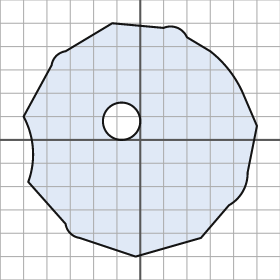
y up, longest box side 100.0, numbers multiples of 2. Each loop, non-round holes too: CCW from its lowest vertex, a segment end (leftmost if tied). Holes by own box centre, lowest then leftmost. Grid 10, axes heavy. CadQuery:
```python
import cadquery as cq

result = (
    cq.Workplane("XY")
    .moveTo(-2.0, -50.0)
    .lineTo(26.0, -42.0)
    .lineTo(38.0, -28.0)
    .threePointArc((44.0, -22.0), (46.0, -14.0))
    .lineTo(50.0, 6.0)
    .lineTo(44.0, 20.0)
    .threePointArc((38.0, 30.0), (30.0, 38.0))
    .lineTo(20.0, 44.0)
    .threePointArc((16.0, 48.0), (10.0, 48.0))
    .lineTo(-12.0, 50.0)
    .lineTo(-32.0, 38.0)
    .threePointArc((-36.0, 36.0), (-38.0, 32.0))
    .lineTo(-50.0, 10.0)
    .threePointArc((-46.0, -4.0), (-48.0, -18.0))
    .lineTo(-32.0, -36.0)
    .threePointArc((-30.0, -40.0), (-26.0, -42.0))
    .close()
    .moveTo(-8.0, 8.0)
    .circle(8.0)
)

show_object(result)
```